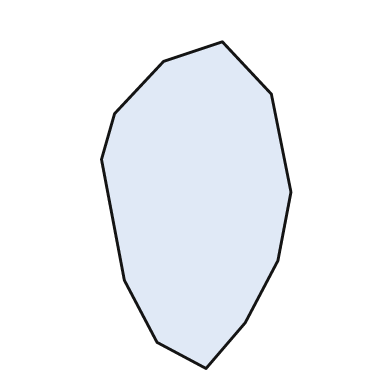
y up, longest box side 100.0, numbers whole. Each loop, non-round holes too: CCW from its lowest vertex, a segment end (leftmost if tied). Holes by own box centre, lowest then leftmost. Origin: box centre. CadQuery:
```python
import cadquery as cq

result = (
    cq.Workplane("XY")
    .moveTo(3.0, -50.0)
    .lineTo(15.0, -36.0)
    .lineTo(25.0, -17.0)
    .lineTo(29.0, 4.0)
    .lineTo(23.0, 34.0)
    .lineTo(8.0, 50.0)
    .lineTo(-10.0, 44.0)
    .lineTo(-25.0, 28.0)
    .lineTo(-29.0, 14.0)
    .lineTo(-22.0, -23.0)
    .lineTo(-12.0, -42.0)
    .close()
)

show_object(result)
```